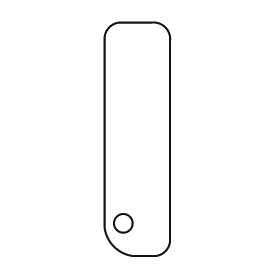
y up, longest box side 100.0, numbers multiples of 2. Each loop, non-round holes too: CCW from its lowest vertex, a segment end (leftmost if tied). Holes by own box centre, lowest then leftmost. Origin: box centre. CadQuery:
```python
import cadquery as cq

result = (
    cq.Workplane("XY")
    .moveTo(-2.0, -50.0)
    .lineTo(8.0, -50.0)
    .threePointArc((12.0, -48.0), (14.0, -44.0))
    .lineTo(14.0, 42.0)
    .threePointArc((12.0, 48.0), (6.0, 50.0))
    .lineTo(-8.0, 50.0)
    .threePointArc((-12.0, 48.0), (-14.0, 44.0))
    .lineTo(-14.0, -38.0)
    .threePointArc((-10.0, -46.0), (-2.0, -50.0))
    .close()
    .moveTo(-6.0, -36.0)
    .circle(4.0)
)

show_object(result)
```